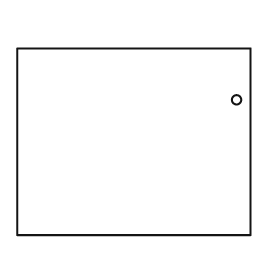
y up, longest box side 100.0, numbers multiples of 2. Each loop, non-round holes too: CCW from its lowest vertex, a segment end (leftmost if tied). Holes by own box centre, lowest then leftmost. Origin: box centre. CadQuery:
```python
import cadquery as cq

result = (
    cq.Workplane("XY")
    .moveTo(-50.0, -40.0)
    .lineTo(50.0, -40.0)
    .lineTo(50.0, 40.0)
    .lineTo(-50.0, 40.0)
    .close()
    .moveTo(44.0, 18.0)
    .circle(2.0)
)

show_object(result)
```